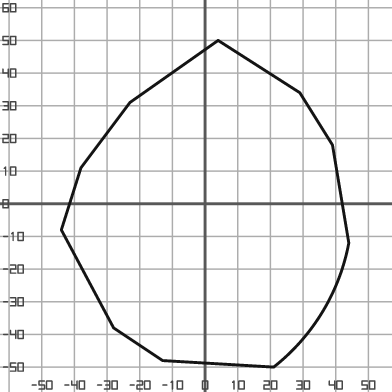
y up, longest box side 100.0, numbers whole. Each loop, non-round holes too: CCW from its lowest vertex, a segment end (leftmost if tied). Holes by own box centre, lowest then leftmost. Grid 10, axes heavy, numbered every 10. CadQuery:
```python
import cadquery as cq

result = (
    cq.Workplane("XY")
    .moveTo(21.0, -50.0)
    .threePointArc((36.0, -33.0), (44.0, -12.0))
    .lineTo(39.0, 18.0)
    .lineTo(29.0, 34.0)
    .lineTo(4.0, 50.0)
    .lineTo(-23.0, 31.0)
    .lineTo(-38.0, 11.0)
    .lineTo(-44.0, -8.0)
    .lineTo(-28.0, -38.0)
    .lineTo(-13.0, -48.0)
    .close()
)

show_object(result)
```